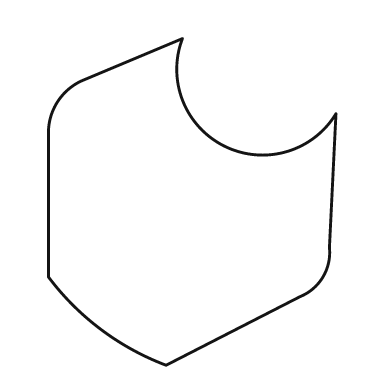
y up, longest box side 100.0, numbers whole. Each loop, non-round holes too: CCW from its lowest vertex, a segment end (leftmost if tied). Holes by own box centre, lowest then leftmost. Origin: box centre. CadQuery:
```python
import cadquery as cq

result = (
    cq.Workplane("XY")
    .moveTo(-8.0, -50.0)
    .lineTo(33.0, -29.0)
    .threePointArc((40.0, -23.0), (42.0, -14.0))
    .lineTo(44.0, 27.0)
    .threePointArc((10.0, 17.0), (-3.0, 50.0))
    .lineTo(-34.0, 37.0)
    .threePointArc((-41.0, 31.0), (-44.0, 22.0))
    .lineTo(-44.0, -23.0)
    .threePointArc((-28.0, -39.0), (-8.0, -50.0))
    .close()
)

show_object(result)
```